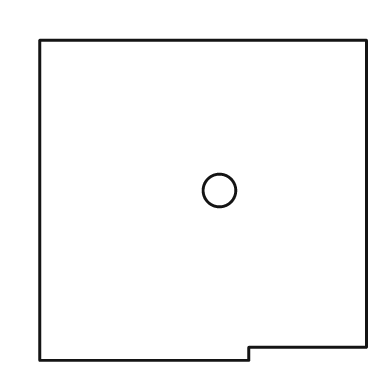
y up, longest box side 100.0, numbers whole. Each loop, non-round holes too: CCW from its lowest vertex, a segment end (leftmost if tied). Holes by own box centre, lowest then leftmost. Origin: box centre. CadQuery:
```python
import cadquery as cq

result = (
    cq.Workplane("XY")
    .moveTo(-50.0, -49.0)
    .lineTo(14.0, -49.0)
    .lineTo(14.0, -45.0)
    .lineTo(50.0, -45.0)
    .lineTo(50.0, 49.0)
    .lineTo(-50.0, 49.0)
    .close()
    .moveTo(5.0, 3.0)
    .circle(5.0)
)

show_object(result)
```